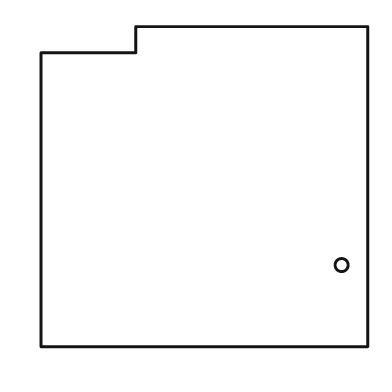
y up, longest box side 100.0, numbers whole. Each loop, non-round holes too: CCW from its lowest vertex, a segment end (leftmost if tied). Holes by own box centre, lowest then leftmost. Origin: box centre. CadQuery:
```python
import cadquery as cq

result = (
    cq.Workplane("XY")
    .moveTo(-50.0, -49.0)
    .lineTo(50.0, -49.0)
    .lineTo(50.0, 49.0)
    .lineTo(-21.0, 49.0)
    .lineTo(-21.0, 41.0)
    .lineTo(-50.0, 41.0)
    .close()
    .moveTo(42.0, -24.0)
    .circle(2.0)
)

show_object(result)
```